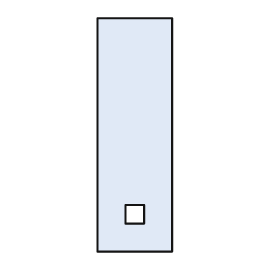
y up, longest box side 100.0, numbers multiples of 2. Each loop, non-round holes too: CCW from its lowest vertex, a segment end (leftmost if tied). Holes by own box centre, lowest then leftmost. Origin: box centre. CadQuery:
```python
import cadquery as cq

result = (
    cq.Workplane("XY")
    .moveTo(-16.0, -50.0)
    .lineTo(16.0, -50.0)
    .lineTo(16.0, 50.0)
    .lineTo(-16.0, 50.0)
    .close()
    .moveTo(-4.0, -38.0)
    .lineTo(4.0, -38.0)
    .lineTo(4.0, -30.0)
    .lineTo(-4.0, -30.0)
    .close()
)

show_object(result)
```